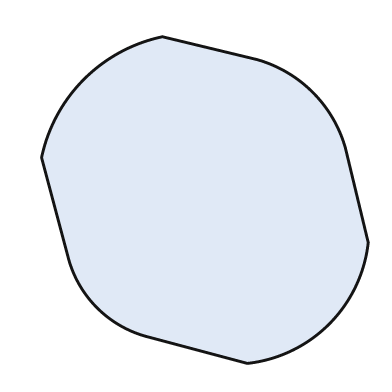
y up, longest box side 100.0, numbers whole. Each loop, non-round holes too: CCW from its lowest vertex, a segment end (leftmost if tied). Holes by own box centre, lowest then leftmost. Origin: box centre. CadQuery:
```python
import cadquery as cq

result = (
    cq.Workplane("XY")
    .moveTo(13.0, -50.0)
    .threePointArc((38.0, -38.0), (50.0, -13.0))
    .lineTo(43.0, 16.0)
    .threePointArc((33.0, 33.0), (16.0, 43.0))
    .lineTo(-13.0, 50.0)
    .threePointArc((-37.0, 37.0), (-50.0, 13.0))
    .lineTo(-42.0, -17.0)
    .threePointArc((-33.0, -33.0), (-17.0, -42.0))
    .close()
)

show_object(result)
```